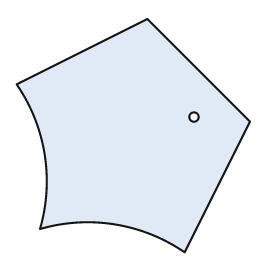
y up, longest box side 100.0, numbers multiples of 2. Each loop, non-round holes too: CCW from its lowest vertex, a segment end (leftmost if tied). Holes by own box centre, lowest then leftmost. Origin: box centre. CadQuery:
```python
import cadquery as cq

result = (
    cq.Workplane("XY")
    .moveTo(22.0, -50.0)
    .lineTo(50.0, 6.0)
    .lineTo(6.0, 50.0)
    .lineTo(-50.0, 22.0)
    .threePointArc((-38.0, -8.0), (-40.0, -40.0))
    .threePointArc((-8.0, -38.0), (22.0, -50.0))
    .close()
    .moveTo(26.0, 8.0)
    .circle(2.0)
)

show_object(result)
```